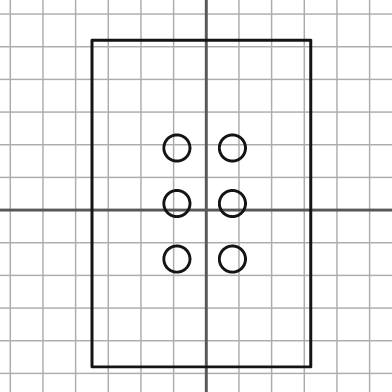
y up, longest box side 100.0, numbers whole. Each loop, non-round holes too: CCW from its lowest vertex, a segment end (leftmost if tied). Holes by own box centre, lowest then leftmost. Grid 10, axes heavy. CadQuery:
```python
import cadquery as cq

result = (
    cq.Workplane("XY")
    .moveTo(-35.0, -48.0)
    .lineTo(32.0, -48.0)
    .lineTo(32.0, 52.0)
    .lineTo(-35.0, 52.0)
    .close()
    .moveTo(-9.0, -15.0)
    .circle(4.0)
    .moveTo(8.0, -15.0)
    .circle(4.0)
    .moveTo(-9.0, 2.0)
    .circle(4.0)
    .moveTo(8.0, 2.0)
    .circle(4.0)
    .moveTo(-9.0, 19.0)
    .circle(4.0)
    .moveTo(8.0, 19.0)
    .circle(4.0)
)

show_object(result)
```